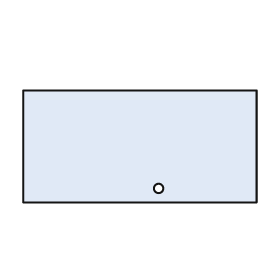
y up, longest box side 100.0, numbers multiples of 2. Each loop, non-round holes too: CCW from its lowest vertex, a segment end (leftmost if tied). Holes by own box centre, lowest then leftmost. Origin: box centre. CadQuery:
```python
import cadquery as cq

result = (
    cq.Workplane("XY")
    .moveTo(-50.0, -24.0)
    .lineTo(50.0, -24.0)
    .lineTo(50.0, 24.0)
    .lineTo(-50.0, 24.0)
    .close()
    .moveTo(8.0, -18.0)
    .circle(2.0)
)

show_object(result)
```